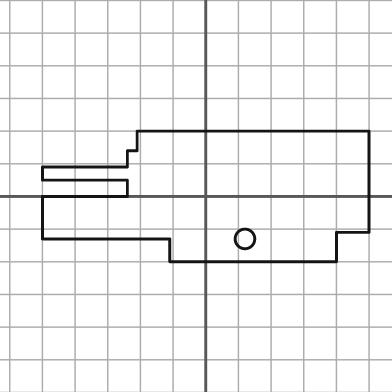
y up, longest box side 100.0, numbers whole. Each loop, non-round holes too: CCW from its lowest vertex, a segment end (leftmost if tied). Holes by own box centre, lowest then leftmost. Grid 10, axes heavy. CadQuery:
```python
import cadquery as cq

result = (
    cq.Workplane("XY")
    .moveTo(-11.0, -20.0)
    .lineTo(40.0, -20.0)
    .lineTo(40.0, -11.0)
    .lineTo(50.0, -11.0)
    .lineTo(50.0, 20.0)
    .lineTo(-21.0, 20.0)
    .lineTo(-21.0, 14.0)
    .lineTo(-24.0, 14.0)
    .lineTo(-24.0, 9.0)
    .lineTo(-50.0, 9.0)
    .lineTo(-50.0, 5.0)
    .lineTo(-24.0, 5.0)
    .lineTo(-24.0, 0.0)
    .lineTo(-50.0, 0.0)
    .lineTo(-50.0, -13.0)
    .lineTo(-11.0, -13.0)
    .close()
    .moveTo(12.0, -13.0)
    .circle(3.0)
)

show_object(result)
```